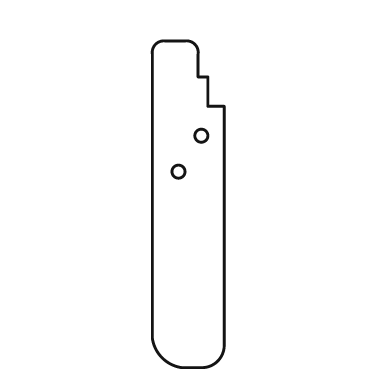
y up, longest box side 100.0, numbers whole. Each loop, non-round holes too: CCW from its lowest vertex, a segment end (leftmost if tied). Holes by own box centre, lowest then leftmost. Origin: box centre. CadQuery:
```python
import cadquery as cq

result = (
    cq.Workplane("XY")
    .moveTo(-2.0, -50.0)
    .lineTo(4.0, -50.0)
    .threePointArc((9.0, -48.0), (11.0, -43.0))
    .lineTo(11.0, 30.0)
    .lineTo(6.0, 30.0)
    .lineTo(6.0, 39.0)
    .lineTo(3.0, 39.0)
    .lineTo(3.0, 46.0)
    .threePointArc((2.0, 49.0), (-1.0, 50.0))
    .lineTo(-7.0, 50.0)
    .threePointArc((-10.0, 49.0), (-11.0, 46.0))
    .lineTo(-11.0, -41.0)
    .threePointArc((-8.0, -47.0), (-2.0, -50.0))
    .close()
    .moveTo(-3.0, 10.0)
    .circle(2.0)
    .moveTo(4.0, 21.0)
    .circle(2.0)
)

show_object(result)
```